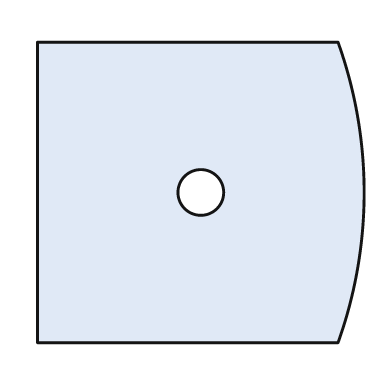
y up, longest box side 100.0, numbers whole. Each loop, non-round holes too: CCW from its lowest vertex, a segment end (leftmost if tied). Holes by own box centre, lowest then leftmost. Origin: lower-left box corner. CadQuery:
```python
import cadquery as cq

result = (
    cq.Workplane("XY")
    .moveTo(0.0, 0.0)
    .lineTo(92.0, 0.0)
    .threePointArc((100.0, 46.0), (92.0, 92.0))
    .lineTo(0.0, 92.0)
    .close()
    .moveTo(50.0, 46.0)
    .circle(7.0)
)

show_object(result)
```